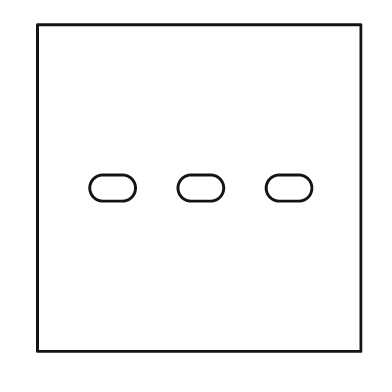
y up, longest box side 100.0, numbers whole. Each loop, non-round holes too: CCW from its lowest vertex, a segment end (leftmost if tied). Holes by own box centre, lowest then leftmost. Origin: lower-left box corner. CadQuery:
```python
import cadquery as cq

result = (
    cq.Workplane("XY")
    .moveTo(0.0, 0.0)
    .lineTo(99.0, 0.0)
    .lineTo(99.0, 100.0)
    .lineTo(0.0, 100.0)
    .close()
    .moveTo(20.0, 46.0)
    .lineTo(26.0, 46.0)
    .threePointArc((30.0, 50.0), (26.0, 54.0))
    .lineTo(20.0, 54.0)
    .threePointArc((16.0, 50.0), (20.0, 46.0))
    .close()
    .moveTo(47.0, 46.0)
    .lineTo(53.0, 46.0)
    .threePointArc((57.0, 50.0), (53.0, 54.0))
    .lineTo(47.0, 54.0)
    .threePointArc((43.0, 50.0), (47.0, 46.0))
    .close()
    .moveTo(74.0, 46.0)
    .lineTo(80.0, 46.0)
    .threePointArc((84.0, 50.0), (80.0, 54.0))
    .lineTo(74.0, 54.0)
    .threePointArc((70.0, 50.0), (74.0, 46.0))
    .close()
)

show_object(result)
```